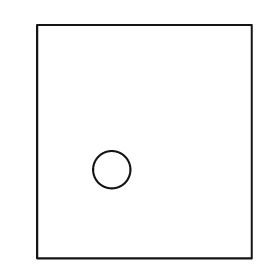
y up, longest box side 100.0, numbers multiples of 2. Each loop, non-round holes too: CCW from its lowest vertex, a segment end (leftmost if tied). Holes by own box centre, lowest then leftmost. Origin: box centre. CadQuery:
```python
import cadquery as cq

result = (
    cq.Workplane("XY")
    .moveTo(-46.0, -50.0)
    .lineTo(46.0, -50.0)
    .lineTo(46.0, 50.0)
    .lineTo(-46.0, 50.0)
    .close()
    .moveTo(-14.0, -12.0)
    .circle(8.0)
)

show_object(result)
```